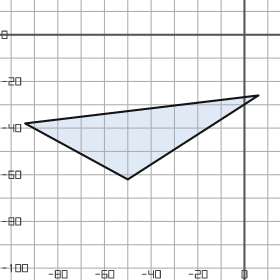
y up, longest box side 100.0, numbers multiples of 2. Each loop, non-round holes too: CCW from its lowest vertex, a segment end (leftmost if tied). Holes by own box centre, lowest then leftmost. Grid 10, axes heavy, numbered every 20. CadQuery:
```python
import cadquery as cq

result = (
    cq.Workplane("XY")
    .moveTo(-50.0, -62.0)
    .lineTo(6.0, -26.0)
    .lineTo(-94.0, -38.0)
    .close()
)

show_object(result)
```